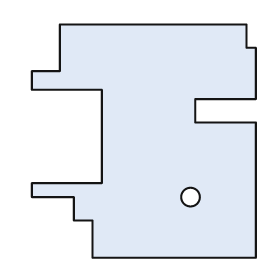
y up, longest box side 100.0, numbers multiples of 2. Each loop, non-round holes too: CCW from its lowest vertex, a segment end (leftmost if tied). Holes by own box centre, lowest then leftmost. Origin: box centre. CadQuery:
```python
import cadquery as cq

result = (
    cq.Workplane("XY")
    .moveTo(-22.0, -50.0)
    .lineTo(48.0, -50.0)
    .lineTo(48.0, 8.0)
    .lineTo(22.0, 8.0)
    .lineTo(22.0, 18.0)
    .lineTo(48.0, 18.0)
    .lineTo(48.0, 40.0)
    .lineTo(44.0, 40.0)
    .lineTo(44.0, 50.0)
    .lineTo(-36.0, 50.0)
    .lineTo(-36.0, 30.0)
    .lineTo(-48.0, 30.0)
    .lineTo(-48.0, 22.0)
    .lineTo(-18.0, 22.0)
    .lineTo(-18.0, -18.0)
    .lineTo(-48.0, -18.0)
    .lineTo(-48.0, -24.0)
    .lineTo(-30.0, -24.0)
    .lineTo(-30.0, -34.0)
    .lineTo(-22.0, -34.0)
    .close()
    .moveTo(20.0, -24.0)
    .circle(4.0)
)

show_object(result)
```